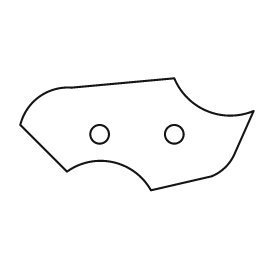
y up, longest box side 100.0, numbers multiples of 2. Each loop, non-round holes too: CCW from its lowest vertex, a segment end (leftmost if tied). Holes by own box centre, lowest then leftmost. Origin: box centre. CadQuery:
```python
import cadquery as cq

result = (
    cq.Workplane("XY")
    .moveTo(6.0, -24.0)
    .lineTo(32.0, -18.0)
    .threePointArc((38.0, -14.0), (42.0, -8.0))
    .lineTo(50.0, 10.0)
    .threePointArc((30.0, 10.0), (16.0, 24.0))
    .lineTo(-28.0, 20.0)
    .threePointArc((-42.0, 16.0), (-50.0, 4.0))
    .lineTo(-30.0, -16.0)
    .threePointArc((-10.0, -12.0), (6.0, -24.0))
    .close()
    .moveTo(-16.0, 0.0)
    .circle(4.0)
    .moveTo(16.0, 0.0)
    .circle(4.0)
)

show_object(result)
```